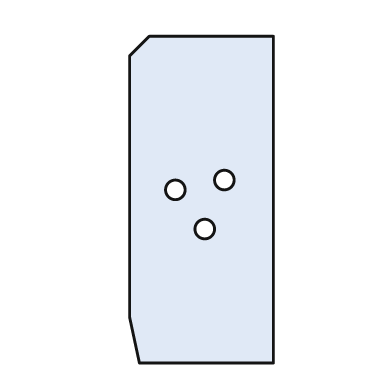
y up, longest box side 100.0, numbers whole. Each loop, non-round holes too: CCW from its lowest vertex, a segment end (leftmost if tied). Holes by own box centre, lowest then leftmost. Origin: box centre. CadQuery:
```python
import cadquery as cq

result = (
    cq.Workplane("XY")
    .moveTo(-19.0, -50.0)
    .lineTo(22.0, -50.0)
    .lineTo(22.0, 50.0)
    .lineTo(-16.0, 50.0)
    .lineTo(-22.0, 44.0)
    .lineTo(-22.0, -36.0)
    .close()
    .moveTo(1.0, -9.0)
    .circle(3.0)
    .moveTo(-8.0, 3.0)
    .circle(3.0)
    .moveTo(7.0, 6.0)
    .circle(3.0)
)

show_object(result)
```